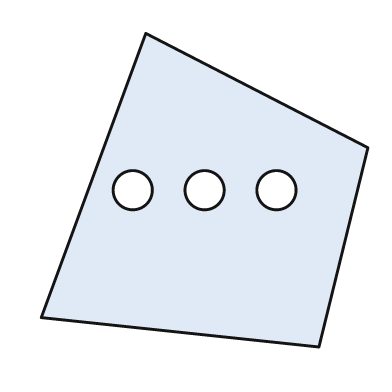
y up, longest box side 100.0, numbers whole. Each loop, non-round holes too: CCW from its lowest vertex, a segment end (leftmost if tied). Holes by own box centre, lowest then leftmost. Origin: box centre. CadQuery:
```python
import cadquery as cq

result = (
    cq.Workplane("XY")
    .moveTo(35.0, -48.0)
    .lineTo(50.0, 13.0)
    .lineTo(-18.0, 48.0)
    .lineTo(-50.0, -39.0)
    .close()
    .moveTo(-22.0, 0.0)
    .circle(6.0)
    .moveTo(0.0, 0.0)
    .circle(6.0)
    .moveTo(22.0, 0.0)
    .circle(6.0)
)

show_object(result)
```